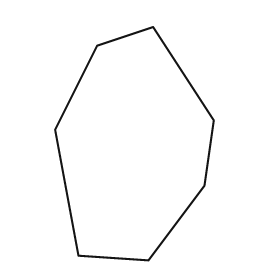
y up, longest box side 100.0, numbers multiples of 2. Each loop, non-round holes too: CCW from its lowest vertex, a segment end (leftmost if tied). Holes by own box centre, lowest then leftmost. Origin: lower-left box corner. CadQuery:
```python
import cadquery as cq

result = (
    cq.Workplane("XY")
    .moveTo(40.0, 0.0)
    .lineTo(64.0, 32.0)
    .lineTo(68.0, 60.0)
    .lineTo(42.0, 100.0)
    .lineTo(18.0, 92.0)
    .lineTo(0.0, 56.0)
    .lineTo(10.0, 2.0)
    .close()
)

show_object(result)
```